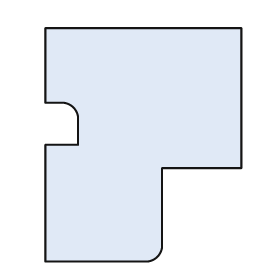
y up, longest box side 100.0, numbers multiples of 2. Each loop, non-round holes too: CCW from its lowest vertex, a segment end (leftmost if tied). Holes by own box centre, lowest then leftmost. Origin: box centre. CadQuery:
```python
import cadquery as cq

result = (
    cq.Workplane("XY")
    .moveTo(-42.0, -50.0)
    .lineTo(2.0, -50.0)
    .threePointArc((6.0, -48.0), (8.0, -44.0))
    .lineTo(8.0, -10.0)
    .lineTo(42.0, -10.0)
    .lineTo(42.0, 50.0)
    .lineTo(-42.0, 50.0)
    .lineTo(-42.0, 18.0)
    .lineTo(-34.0, 18.0)
    .threePointArc((-30.0, 16.0), (-28.0, 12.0))
    .lineTo(-28.0, 0.0)
    .lineTo(-42.0, 0.0)
    .close()
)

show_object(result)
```